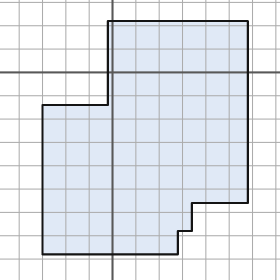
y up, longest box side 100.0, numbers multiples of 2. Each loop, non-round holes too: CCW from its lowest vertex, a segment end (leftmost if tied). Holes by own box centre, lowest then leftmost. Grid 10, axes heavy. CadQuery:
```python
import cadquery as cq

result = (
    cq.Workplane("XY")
    .moveTo(-30.0, -78.0)
    .lineTo(28.0, -78.0)
    .lineTo(28.0, -68.0)
    .lineTo(34.0, -68.0)
    .lineTo(34.0, -56.0)
    .lineTo(58.0, -56.0)
    .lineTo(58.0, 22.0)
    .lineTo(-2.0, 22.0)
    .lineTo(-2.0, -14.0)
    .lineTo(-30.0, -14.0)
    .close()
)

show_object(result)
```